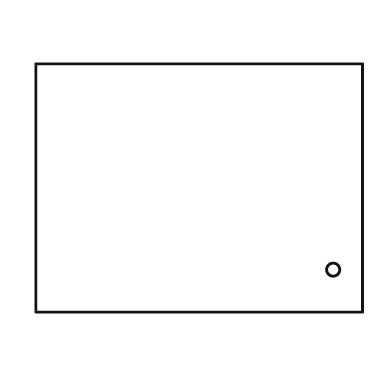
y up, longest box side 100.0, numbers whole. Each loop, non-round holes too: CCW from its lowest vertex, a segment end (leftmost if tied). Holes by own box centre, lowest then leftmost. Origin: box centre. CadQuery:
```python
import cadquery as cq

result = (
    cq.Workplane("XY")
    .moveTo(-50.0, -38.0)
    .lineTo(50.0, -38.0)
    .lineTo(50.0, 38.0)
    .lineTo(-50.0, 38.0)
    .close()
    .moveTo(41.0, -25.0)
    .circle(2.0)
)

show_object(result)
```